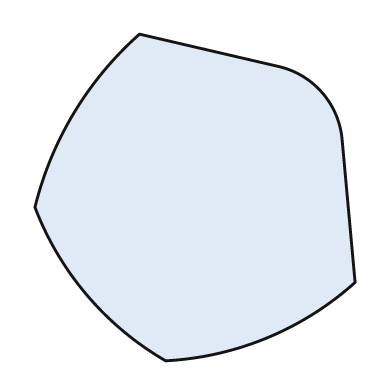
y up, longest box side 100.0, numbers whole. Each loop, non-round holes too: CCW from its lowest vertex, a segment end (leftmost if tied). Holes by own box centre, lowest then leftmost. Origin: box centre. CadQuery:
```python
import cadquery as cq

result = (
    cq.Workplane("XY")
    .moveTo(-9.0, -50.0)
    .threePointArc((22.0, -43.0), (49.0, -26.0))
    .lineTo(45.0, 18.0)
    .threePointArc((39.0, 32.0), (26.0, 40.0))
    .lineTo(-17.0, 50.0)
    .threePointArc((-37.0, 26.0), (-49.0, -3.0))
    .threePointArc((-33.0, -30.0), (-9.0, -50.0))
    .close()
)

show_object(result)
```